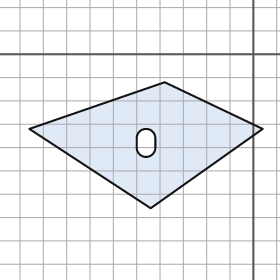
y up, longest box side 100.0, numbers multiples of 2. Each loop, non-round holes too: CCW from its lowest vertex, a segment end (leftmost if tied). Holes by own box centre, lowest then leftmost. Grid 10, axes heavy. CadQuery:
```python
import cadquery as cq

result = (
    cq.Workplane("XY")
    .moveTo(-44.0, -66.0)
    .lineTo(4.0, -32.0)
    .lineTo(-38.0, -12.0)
    .lineTo(-96.0, -32.0)
    .close()
    .moveTo(-50.0, -40.0)
    .threePointArc((-46.0, -44.0), (-42.0, -40.0))
    .lineTo(-42.0, -36.0)
    .threePointArc((-46.0, -32.0), (-50.0, -36.0))
    .close()
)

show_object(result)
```